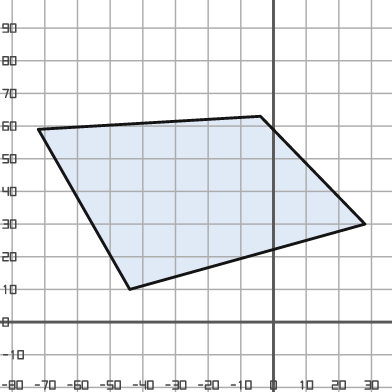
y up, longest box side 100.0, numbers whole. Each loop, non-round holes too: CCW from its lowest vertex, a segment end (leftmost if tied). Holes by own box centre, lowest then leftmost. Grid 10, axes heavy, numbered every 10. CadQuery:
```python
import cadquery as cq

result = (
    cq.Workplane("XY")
    .moveTo(-44.0, 10.0)
    .lineTo(28.0, 30.0)
    .lineTo(-4.0, 63.0)
    .lineTo(-72.0, 59.0)
    .close()
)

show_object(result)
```